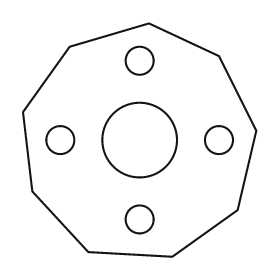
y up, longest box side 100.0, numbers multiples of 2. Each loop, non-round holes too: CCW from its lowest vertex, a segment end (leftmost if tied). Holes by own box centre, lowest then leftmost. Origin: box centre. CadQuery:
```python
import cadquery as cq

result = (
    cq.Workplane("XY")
    .moveTo(14.0, -50.0)
    .lineTo(42.0, -30.0)
    .lineTo(50.0, 4.0)
    .lineTo(34.0, 36.0)
    .lineTo(4.0, 50.0)
    .lineTo(-30.0, 40.0)
    .lineTo(-50.0, 12.0)
    .lineTo(-46.0, -22.0)
    .lineTo(-22.0, -48.0)
    .close()
    .moveTo(0.0, -34.0)
    .circle(6.0)
    .moveTo(-34.0, 0.0)
    .circle(6.0)
    .moveTo(0.0, 0.0)
    .circle(16.0)
    .moveTo(34.0, 0.0)
    .circle(6.0)
    .moveTo(0.0, 34.0)
    .circle(6.0)
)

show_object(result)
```